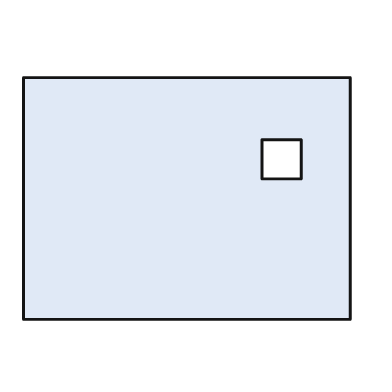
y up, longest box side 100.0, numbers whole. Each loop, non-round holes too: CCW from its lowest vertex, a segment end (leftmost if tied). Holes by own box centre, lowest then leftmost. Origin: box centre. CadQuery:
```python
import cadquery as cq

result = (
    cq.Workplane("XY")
    .moveTo(-50.0, -37.0)
    .lineTo(50.0, -37.0)
    .lineTo(50.0, 37.0)
    .lineTo(-50.0, 37.0)
    .close()
    .moveTo(23.0, 6.0)
    .lineTo(35.0, 6.0)
    .lineTo(35.0, 18.0)
    .lineTo(23.0, 18.0)
    .close()
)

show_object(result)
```